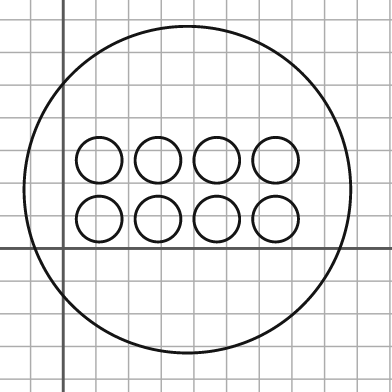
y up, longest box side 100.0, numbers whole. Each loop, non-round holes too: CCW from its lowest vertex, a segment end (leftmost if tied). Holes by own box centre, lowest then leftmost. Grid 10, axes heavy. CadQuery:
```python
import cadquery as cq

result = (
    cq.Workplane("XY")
    .moveTo(38.0, 18.0)
    .circle(50.0)
    .moveTo(11.0, 9.0)
    .circle(7.0)
    .moveTo(29.0, 9.0)
    .circle(7.0)
    .moveTo(47.0, 9.0)
    .circle(7.0)
    .moveTo(65.0, 9.0)
    .circle(7.0)
    .moveTo(11.0, 27.0)
    .circle(7.0)
    .moveTo(29.0, 27.0)
    .circle(7.0)
    .moveTo(47.0, 27.0)
    .circle(7.0)
    .moveTo(65.0, 27.0)
    .circle(7.0)
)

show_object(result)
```